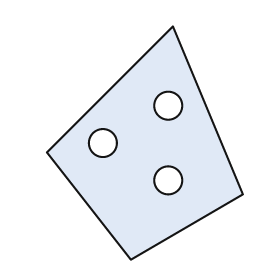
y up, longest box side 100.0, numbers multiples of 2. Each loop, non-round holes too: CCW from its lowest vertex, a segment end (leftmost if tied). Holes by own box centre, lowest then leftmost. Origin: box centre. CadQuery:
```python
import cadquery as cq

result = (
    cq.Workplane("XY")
    .moveTo(-6.0, -50.0)
    .lineTo(42.0, -22.0)
    .lineTo(12.0, 50.0)
    .lineTo(-42.0, -4.0)
    .close()
    .moveTo(10.0, -16.0)
    .circle(6.0)
    .moveTo(-18.0, 0.0)
    .circle(6.0)
    .moveTo(10.0, 16.0)
    .circle(6.0)
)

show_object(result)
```